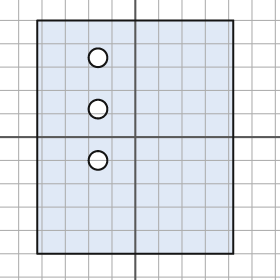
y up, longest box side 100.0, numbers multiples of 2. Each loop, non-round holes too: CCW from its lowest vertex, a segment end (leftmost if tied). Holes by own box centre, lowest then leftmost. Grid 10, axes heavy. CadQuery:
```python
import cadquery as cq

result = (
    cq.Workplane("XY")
    .moveTo(-42.0, -50.0)
    .lineTo(42.0, -50.0)
    .lineTo(42.0, 50.0)
    .lineTo(-42.0, 50.0)
    .close()
    .moveTo(-16.0, -10.0)
    .circle(4.0)
    .moveTo(-16.0, 12.0)
    .circle(4.0)
    .moveTo(-16.0, 34.0)
    .circle(4.0)
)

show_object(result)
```